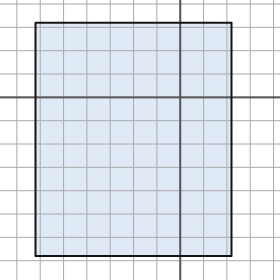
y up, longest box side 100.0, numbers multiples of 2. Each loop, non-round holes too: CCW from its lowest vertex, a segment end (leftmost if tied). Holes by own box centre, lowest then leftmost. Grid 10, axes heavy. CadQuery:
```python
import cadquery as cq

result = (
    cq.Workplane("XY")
    .moveTo(-62.0, -68.0)
    .lineTo(22.0, -68.0)
    .lineTo(22.0, 32.0)
    .lineTo(-62.0, 32.0)
    .close()
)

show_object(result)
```